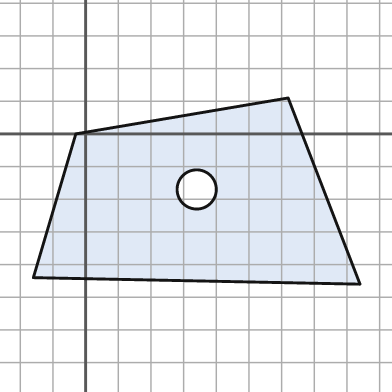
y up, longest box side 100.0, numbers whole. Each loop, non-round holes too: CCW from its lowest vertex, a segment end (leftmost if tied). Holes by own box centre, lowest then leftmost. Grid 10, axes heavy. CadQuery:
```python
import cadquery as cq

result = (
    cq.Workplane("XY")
    .moveTo(84.0, -46.0)
    .lineTo(62.0, 11.0)
    .lineTo(-3.0, 0.0)
    .lineTo(-16.0, -44.0)
    .close()
    .moveTo(34.0, -17.0)
    .circle(6.0)
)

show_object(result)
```